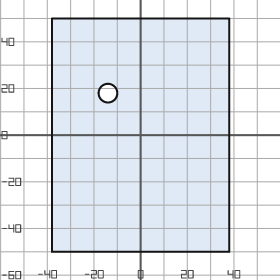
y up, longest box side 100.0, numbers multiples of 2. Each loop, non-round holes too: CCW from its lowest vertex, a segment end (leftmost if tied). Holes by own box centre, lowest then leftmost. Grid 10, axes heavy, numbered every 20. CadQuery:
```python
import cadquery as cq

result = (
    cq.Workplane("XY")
    .moveTo(-38.0, -50.0)
    .lineTo(38.0, -50.0)
    .lineTo(38.0, 50.0)
    .lineTo(-38.0, 50.0)
    .close()
    .moveTo(-14.0, 18.0)
    .circle(4.0)
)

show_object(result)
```